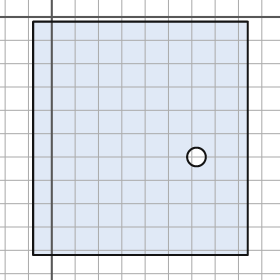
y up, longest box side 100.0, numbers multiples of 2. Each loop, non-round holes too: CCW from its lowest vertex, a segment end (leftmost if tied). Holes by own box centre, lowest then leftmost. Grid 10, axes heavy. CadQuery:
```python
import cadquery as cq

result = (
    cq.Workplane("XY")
    .moveTo(-8.0, -102.0)
    .lineTo(84.0, -102.0)
    .lineTo(84.0, -2.0)
    .lineTo(-8.0, -2.0)
    .close()
    .moveTo(62.0, -60.0)
    .circle(4.0)
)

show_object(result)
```